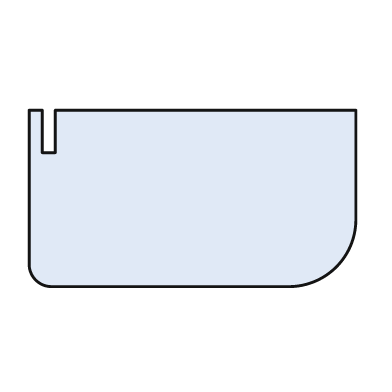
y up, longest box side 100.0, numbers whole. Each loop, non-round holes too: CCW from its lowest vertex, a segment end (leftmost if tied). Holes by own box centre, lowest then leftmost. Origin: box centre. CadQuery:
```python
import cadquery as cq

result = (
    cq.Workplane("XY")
    .moveTo(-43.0, -27.0)
    .lineTo(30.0, -27.0)
    .threePointArc((44.0, -21.0), (50.0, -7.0))
    .lineTo(50.0, 27.0)
    .lineTo(-42.0, 27.0)
    .lineTo(-42.0, 14.0)
    .lineTo(-46.0, 14.0)
    .lineTo(-46.0, 27.0)
    .lineTo(-50.0, 27.0)
    .lineTo(-50.0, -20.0)
    .threePointArc((-48.0, -25.0), (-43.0, -27.0))
    .close()
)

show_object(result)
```